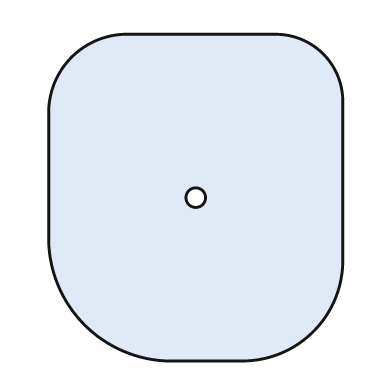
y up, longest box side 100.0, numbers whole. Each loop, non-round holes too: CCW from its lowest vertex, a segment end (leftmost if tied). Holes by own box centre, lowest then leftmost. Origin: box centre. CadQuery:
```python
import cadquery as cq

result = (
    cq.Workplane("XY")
    .moveTo(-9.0, -50.0)
    .lineTo(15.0, -50.0)
    .threePointArc((36.0, -41.0), (45.0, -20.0))
    .lineTo(45.0, 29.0)
    .threePointArc((39.0, 44.0), (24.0, 50.0))
    .lineTo(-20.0, 50.0)
    .threePointArc((-38.0, 43.0), (-45.0, 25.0))
    .lineTo(-45.0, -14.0)
    .threePointArc((-34.0, -39.0), (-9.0, -50.0))
    .close()
    .moveTo(0.0, 0.0)
    .circle(3.0)
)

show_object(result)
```